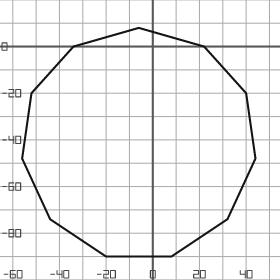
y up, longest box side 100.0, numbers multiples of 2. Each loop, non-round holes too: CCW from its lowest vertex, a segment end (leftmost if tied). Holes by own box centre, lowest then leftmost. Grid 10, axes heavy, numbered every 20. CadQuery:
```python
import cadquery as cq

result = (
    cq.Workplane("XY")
    .moveTo(-20.0, -90.0)
    .lineTo(8.0, -90.0)
    .lineTo(32.0, -74.0)
    .lineTo(44.0, -48.0)
    .lineTo(40.0, -20.0)
    .lineTo(22.0, 0.0)
    .lineTo(-6.0, 8.0)
    .lineTo(-34.0, 0.0)
    .lineTo(-52.0, -20.0)
    .lineTo(-56.0, -48.0)
    .lineTo(-44.0, -74.0)
    .close()
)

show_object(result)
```